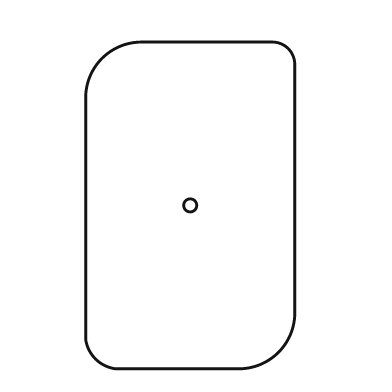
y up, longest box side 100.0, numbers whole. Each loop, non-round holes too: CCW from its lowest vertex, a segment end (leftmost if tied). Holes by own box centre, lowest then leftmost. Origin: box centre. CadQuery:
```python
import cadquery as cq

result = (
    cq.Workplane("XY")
    .moveTo(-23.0, -50.0)
    .lineTo(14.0, -50.0)
    .threePointArc((27.0, -45.0), (32.0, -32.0))
    .lineTo(32.0, 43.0)
    .threePointArc((30.0, 48.0), (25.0, 50.0))
    .lineTo(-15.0, 50.0)
    .threePointArc((-27.0, 45.0), (-32.0, 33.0))
    .lineTo(-32.0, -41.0)
    .threePointArc((-29.0, -47.0), (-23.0, -50.0))
    .close()
    .moveTo(0.0, 0.0)
    .circle(2.0)
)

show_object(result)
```